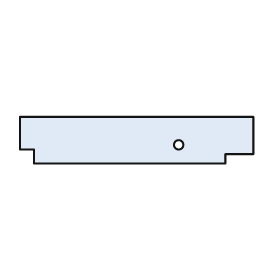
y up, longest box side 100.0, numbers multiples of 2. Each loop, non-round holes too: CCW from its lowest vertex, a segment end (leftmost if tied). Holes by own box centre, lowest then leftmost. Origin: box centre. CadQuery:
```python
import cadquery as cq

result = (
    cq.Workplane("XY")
    .moveTo(-44.0, -10.0)
    .lineTo(38.0, -10.0)
    .lineTo(38.0, -6.0)
    .lineTo(50.0, -6.0)
    .lineTo(50.0, 10.0)
    .lineTo(-50.0, 10.0)
    .lineTo(-50.0, -4.0)
    .lineTo(-44.0, -4.0)
    .close()
    .moveTo(18.0, -2.0)
    .circle(2.0)
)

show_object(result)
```